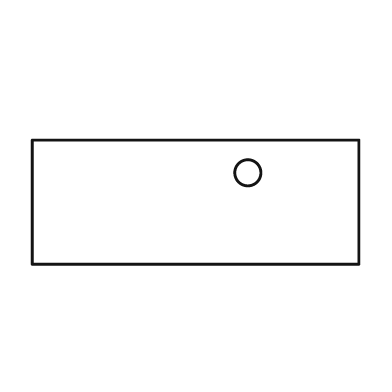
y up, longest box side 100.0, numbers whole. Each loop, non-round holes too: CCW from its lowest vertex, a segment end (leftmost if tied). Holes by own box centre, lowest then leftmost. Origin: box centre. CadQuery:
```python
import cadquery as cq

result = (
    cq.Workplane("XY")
    .moveTo(-50.0, -19.0)
    .lineTo(50.0, -19.0)
    .lineTo(50.0, 19.0)
    .lineTo(-50.0, 19.0)
    .close()
    .moveTo(16.0, 9.0)
    .circle(4.0)
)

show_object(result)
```